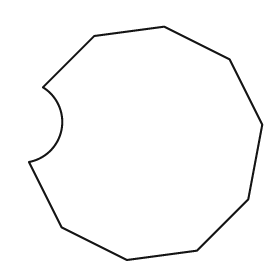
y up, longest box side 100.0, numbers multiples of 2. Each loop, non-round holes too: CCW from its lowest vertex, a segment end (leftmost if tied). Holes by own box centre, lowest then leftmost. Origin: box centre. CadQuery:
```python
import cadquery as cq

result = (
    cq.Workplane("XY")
    .moveTo(-8.0, -50.0)
    .lineTo(22.0, -46.0)
    .lineTo(44.0, -24.0)
    .lineTo(50.0, 8.0)
    .lineTo(36.0, 36.0)
    .lineTo(8.0, 50.0)
    .lineTo(-22.0, 46.0)
    .lineTo(-44.0, 24.0)
    .threePointArc((-36.0, 6.0), (-50.0, -8.0))
    .lineTo(-36.0, -36.0)
    .close()
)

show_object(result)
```